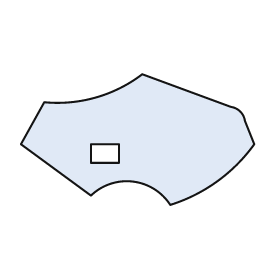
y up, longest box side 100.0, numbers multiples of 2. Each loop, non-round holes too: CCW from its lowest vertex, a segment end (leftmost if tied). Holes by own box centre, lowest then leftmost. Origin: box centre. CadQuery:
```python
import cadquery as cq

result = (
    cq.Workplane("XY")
    .moveTo(14.0, -28.0)
    .threePointArc((34.0, -18.0), (50.0, -2.0))
    .lineTo(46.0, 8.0)
    .threePointArc((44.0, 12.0), (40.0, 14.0))
    .lineTo(2.0, 28.0)
    .threePointArc((-18.0, 18.0), (-40.0, 16.0))
    .lineTo(-50.0, -2.0)
    .lineTo(-20.0, -24.0)
    .threePointArc((-2.0, -18.0), (14.0, -28.0))
    .close()
    .moveTo(-20.0, -10.0)
    .lineTo(-8.0, -10.0)
    .lineTo(-8.0, -2.0)
    .lineTo(-20.0, -2.0)
    .close()
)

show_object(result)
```